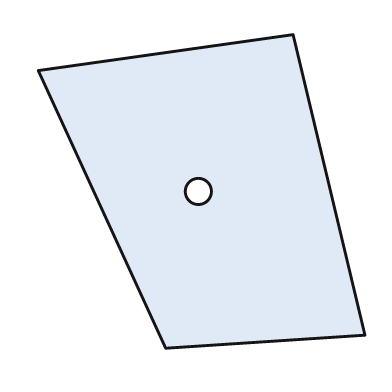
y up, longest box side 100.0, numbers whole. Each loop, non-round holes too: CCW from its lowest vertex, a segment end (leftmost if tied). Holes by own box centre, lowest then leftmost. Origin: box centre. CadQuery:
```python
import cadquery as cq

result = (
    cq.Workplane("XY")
    .moveTo(-11.0, -48.0)
    .lineTo(50.0, -44.0)
    .lineTo(28.0, 48.0)
    .lineTo(-50.0, 37.0)
    .close()
    .moveTo(-1.0, 0.0)
    .circle(4.0)
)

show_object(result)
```